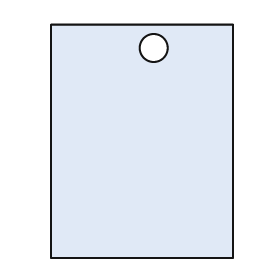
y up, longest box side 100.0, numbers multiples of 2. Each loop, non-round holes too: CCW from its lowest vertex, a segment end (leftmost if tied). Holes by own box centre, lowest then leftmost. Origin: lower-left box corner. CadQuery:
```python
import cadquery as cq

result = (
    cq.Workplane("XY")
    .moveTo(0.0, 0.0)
    .lineTo(78.0, 0.0)
    .lineTo(78.0, 100.0)
    .lineTo(0.0, 100.0)
    .close()
    .moveTo(44.0, 90.0)
    .circle(6.0)
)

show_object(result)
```